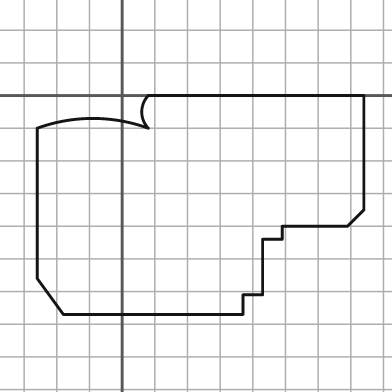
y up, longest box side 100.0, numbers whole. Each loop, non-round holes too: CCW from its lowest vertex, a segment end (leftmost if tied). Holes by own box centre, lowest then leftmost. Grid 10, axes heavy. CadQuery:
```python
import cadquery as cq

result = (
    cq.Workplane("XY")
    .moveTo(-18.0, -67.0)
    .lineTo(37.0, -67.0)
    .lineTo(37.0, -61.0)
    .lineTo(43.0, -61.0)
    .lineTo(43.0, -44.0)
    .lineTo(49.0, -44.0)
    .lineTo(49.0, -40.0)
    .lineTo(69.0, -40.0)
    .lineTo(74.0, -35.0)
    .lineTo(74.0, 0.0)
    .lineTo(8.0, 0.0)
    .threePointArc((6.0, -5.0), (8.0, -10.0))
    .threePointArc((-9.0, -7.0), (-26.0, -10.0))
    .lineTo(-26.0, -56.0)
    .close()
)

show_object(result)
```